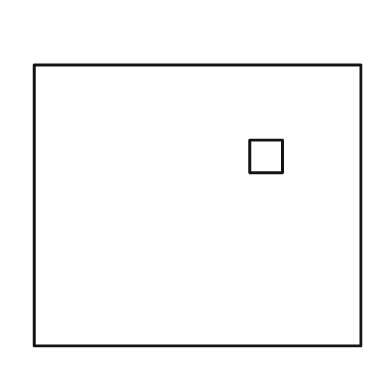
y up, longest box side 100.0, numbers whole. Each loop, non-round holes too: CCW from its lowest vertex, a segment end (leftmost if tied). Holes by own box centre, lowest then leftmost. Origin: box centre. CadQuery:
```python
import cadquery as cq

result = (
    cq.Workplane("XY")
    .moveTo(-50.0, -43.0)
    .lineTo(50.0, -43.0)
    .lineTo(50.0, 43.0)
    .lineTo(-50.0, 43.0)
    .close()
    .moveTo(16.0, 10.0)
    .lineTo(26.0, 10.0)
    .lineTo(26.0, 20.0)
    .lineTo(16.0, 20.0)
    .close()
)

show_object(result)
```